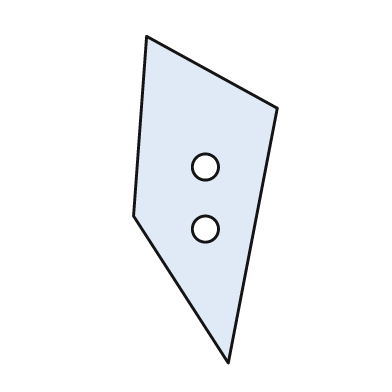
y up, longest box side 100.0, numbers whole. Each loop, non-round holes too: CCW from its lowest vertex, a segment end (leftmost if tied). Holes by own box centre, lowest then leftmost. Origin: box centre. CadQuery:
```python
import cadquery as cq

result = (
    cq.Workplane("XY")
    .moveTo(7.0, -50.0)
    .lineTo(22.0, 28.0)
    .lineTo(-18.0, 50.0)
    .lineTo(-22.0, -5.0)
    .close()
    .moveTo(0.0, -9.0)
    .circle(4.0)
    .moveTo(0.0, 10.0)
    .circle(4.0)
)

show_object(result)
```